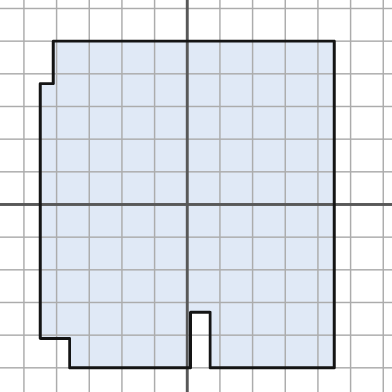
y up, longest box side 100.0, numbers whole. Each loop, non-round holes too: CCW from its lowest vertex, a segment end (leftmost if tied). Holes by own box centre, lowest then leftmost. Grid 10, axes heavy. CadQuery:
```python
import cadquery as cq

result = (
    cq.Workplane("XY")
    .moveTo(-36.0, -50.0)
    .lineTo(1.0, -50.0)
    .lineTo(1.0, -33.0)
    .lineTo(7.0, -33.0)
    .lineTo(7.0, -50.0)
    .lineTo(45.0, -50.0)
    .lineTo(45.0, 50.0)
    .lineTo(-41.0, 50.0)
    .lineTo(-41.0, 37.0)
    .lineTo(-45.0, 37.0)
    .lineTo(-45.0, -41.0)
    .lineTo(-36.0, -41.0)
    .close()
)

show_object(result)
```